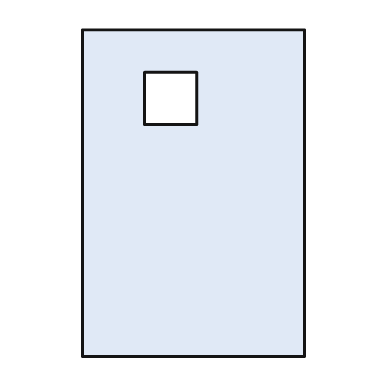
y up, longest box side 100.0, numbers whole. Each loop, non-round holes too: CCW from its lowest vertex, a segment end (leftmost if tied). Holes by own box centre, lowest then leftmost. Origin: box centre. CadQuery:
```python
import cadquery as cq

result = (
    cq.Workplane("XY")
    .moveTo(-34.0, -50.0)
    .lineTo(34.0, -50.0)
    .lineTo(34.0, 50.0)
    .lineTo(-34.0, 50.0)
    .close()
    .moveTo(-15.0, 21.0)
    .lineTo(1.0, 21.0)
    .lineTo(1.0, 37.0)
    .lineTo(-15.0, 37.0)
    .close()
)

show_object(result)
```